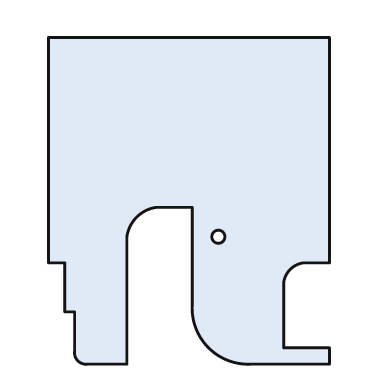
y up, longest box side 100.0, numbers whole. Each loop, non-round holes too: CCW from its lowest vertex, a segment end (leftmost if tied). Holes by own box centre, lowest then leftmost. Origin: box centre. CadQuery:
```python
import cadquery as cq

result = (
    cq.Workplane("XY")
    .moveTo(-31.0, -50.0)
    .lineTo(-19.0, -50.0)
    .lineTo(-19.0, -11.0)
    .threePointArc((-16.0, -5.0), (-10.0, -2.0))
    .lineTo(1.0, -2.0)
    .lineTo(1.0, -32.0)
    .threePointArc((6.0, -45.0), (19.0, -50.0))
    .lineTo(43.0, -50.0)
    .lineTo(43.0, -45.0)
    .lineTo(29.0, -45.0)
    .lineTo(29.0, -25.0)
    .threePointArc((31.0, -21.0), (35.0, -19.0))
    .lineTo(43.0, -19.0)
    .lineTo(43.0, 50.0)
    .lineTo(-43.0, 50.0)
    .lineTo(-43.0, -19.0)
    .lineTo(-38.0, -19.0)
    .lineTo(-38.0, -34.0)
    .lineTo(-35.0, -34.0)
    .lineTo(-35.0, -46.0)
    .threePointArc((-34.0, -49.0), (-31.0, -50.0))
    .close()
    .moveTo(9.0, -11.0)
    .circle(2.0)
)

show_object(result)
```